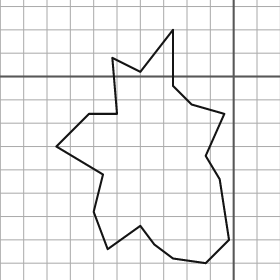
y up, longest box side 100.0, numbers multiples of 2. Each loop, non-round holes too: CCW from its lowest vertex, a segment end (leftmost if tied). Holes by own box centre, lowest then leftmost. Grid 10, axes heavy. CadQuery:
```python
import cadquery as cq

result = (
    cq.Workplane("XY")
    .moveTo(-12.0, -80.0)
    .lineTo(-2.0, -70.0)
    .lineTo(-6.0, -44.0)
    .lineTo(-12.0, -34.0)
    .lineTo(-4.0, -16.0)
    .lineTo(-18.0, -12.0)
    .lineTo(-26.0, -4.0)
    .lineTo(-26.0, 20.0)
    .lineTo(-40.0, 2.0)
    .lineTo(-52.0, 8.0)
    .lineTo(-50.0, -16.0)
    .lineTo(-62.0, -16.0)
    .lineTo(-76.0, -30.0)
    .lineTo(-56.0, -42.0)
    .lineTo(-60.0, -58.0)
    .lineTo(-54.0, -74.0)
    .lineTo(-40.0, -64.0)
    .lineTo(-34.0, -72.0)
    .lineTo(-26.0, -78.0)
    .close()
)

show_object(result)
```